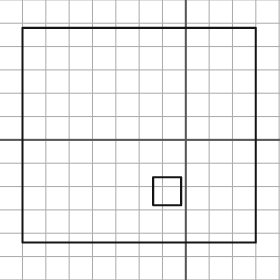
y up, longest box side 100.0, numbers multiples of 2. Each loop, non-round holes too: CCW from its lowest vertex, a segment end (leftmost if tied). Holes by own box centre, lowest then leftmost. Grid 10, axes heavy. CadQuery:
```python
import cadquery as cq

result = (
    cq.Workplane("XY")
    .moveTo(-70.0, -44.0)
    .lineTo(30.0, -44.0)
    .lineTo(30.0, 48.0)
    .lineTo(-70.0, 48.0)
    .close()
    .moveTo(-14.0, -28.0)
    .lineTo(-2.0, -28.0)
    .lineTo(-2.0, -16.0)
    .lineTo(-14.0, -16.0)
    .close()
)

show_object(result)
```